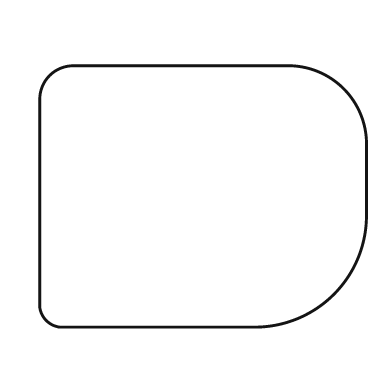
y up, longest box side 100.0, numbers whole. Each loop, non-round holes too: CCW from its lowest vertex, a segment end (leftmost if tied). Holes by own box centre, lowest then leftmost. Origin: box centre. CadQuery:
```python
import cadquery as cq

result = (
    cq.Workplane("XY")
    .moveTo(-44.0, -40.0)
    .lineTo(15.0, -40.0)
    .threePointArc((40.0, -30.0), (50.0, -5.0))
    .lineTo(50.0, 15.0)
    .threePointArc((43.0, 33.0), (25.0, 40.0))
    .lineTo(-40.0, 40.0)
    .threePointArc((-47.0, 37.0), (-50.0, 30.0))
    .lineTo(-50.0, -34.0)
    .threePointArc((-48.0, -38.0), (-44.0, -40.0))
    .close()
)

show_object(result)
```